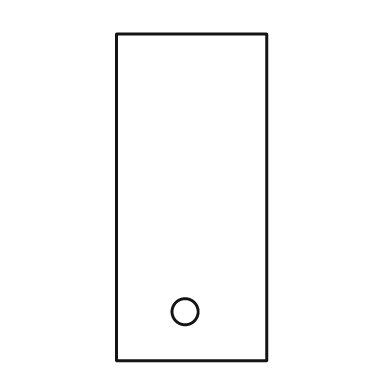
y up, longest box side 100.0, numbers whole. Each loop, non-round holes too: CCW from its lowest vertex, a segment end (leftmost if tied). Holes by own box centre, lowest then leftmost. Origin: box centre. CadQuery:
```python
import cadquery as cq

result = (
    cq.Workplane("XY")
    .moveTo(-23.0, -50.0)
    .lineTo(23.0, -50.0)
    .lineTo(23.0, 50.0)
    .lineTo(-23.0, 50.0)
    .close()
    .moveTo(-2.0, -35.0)
    .circle(4.0)
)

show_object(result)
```